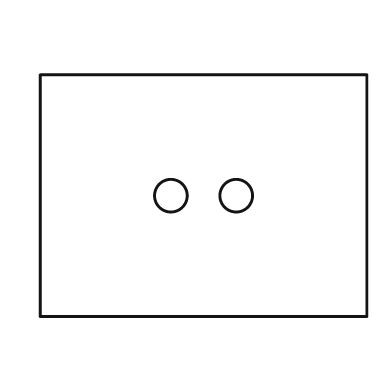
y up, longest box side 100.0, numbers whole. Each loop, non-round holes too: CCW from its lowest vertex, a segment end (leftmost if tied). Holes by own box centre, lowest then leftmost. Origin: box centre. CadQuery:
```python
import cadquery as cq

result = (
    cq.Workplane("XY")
    .moveTo(-50.0, -37.0)
    .lineTo(50.0, -37.0)
    .lineTo(50.0, 37.0)
    .lineTo(-50.0, 37.0)
    .close()
    .moveTo(-10.0, 0.0)
    .circle(5.0)
    .moveTo(10.0, 0.0)
    .circle(5.0)
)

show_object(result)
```